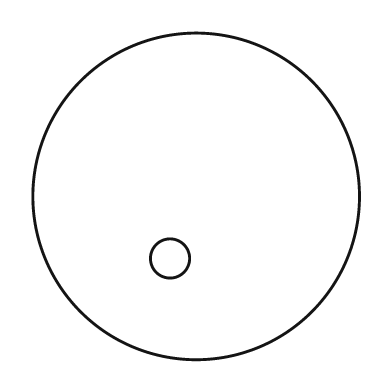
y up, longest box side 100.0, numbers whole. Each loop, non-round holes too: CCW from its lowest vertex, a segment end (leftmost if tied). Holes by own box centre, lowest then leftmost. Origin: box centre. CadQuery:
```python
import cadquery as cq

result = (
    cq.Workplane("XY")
    .moveTo(0.0, 0.0)
    .circle(50.0)
    .moveTo(-8.0, -19.0)
    .circle(6.0)
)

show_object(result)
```